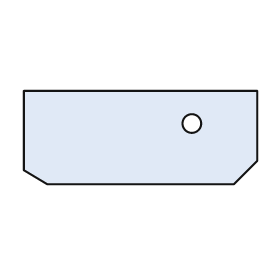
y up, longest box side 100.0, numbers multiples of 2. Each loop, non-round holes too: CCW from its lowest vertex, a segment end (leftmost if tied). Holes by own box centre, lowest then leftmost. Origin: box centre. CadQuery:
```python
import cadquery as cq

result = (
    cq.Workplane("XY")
    .moveTo(-40.0, -20.0)
    .lineTo(40.0, -20.0)
    .lineTo(50.0, -10.0)
    .lineTo(50.0, 20.0)
    .lineTo(-50.0, 20.0)
    .lineTo(-50.0, -14.0)
    .close()
    .moveTo(22.0, 6.0)
    .circle(4.0)
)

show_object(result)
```